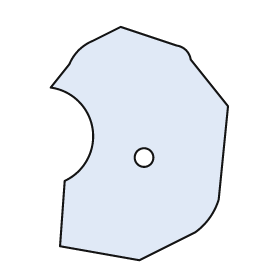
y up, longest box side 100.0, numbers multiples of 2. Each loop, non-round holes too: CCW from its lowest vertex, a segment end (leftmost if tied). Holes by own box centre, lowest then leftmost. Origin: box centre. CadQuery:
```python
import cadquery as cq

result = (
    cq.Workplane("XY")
    .moveTo(0.0, -50.0)
    .lineTo(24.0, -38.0)
    .threePointArc((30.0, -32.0), (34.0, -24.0))
    .lineTo(38.0, 16.0)
    .lineTo(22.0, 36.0)
    .threePointArc((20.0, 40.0), (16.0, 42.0))
    .lineTo(-8.0, 50.0)
    .lineTo(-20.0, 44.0)
    .threePointArc((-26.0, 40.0), (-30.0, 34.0))
    .lineTo(-38.0, 24.0)
    .threePointArc((-20.0, 6.0), (-32.0, -16.0))
    .lineTo(-34.0, -44.0)
    .close()
    .moveTo(2.0, -6.0)
    .circle(4.0)
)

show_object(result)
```